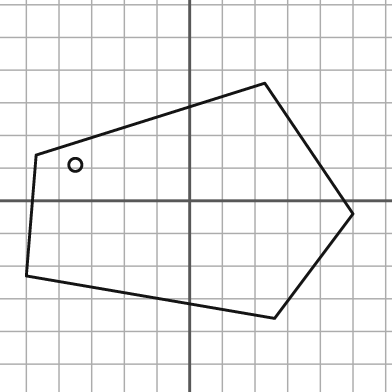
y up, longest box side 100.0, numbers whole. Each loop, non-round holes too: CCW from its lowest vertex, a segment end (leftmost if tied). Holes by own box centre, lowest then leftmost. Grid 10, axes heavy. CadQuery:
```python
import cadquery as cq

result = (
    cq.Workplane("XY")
    .moveTo(26.0, -36.0)
    .lineTo(50.0, -4.0)
    .lineTo(23.0, 36.0)
    .lineTo(-47.0, 14.0)
    .lineTo(-50.0, -23.0)
    .close()
    .moveTo(-35.0, 11.0)
    .circle(2.0)
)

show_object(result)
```